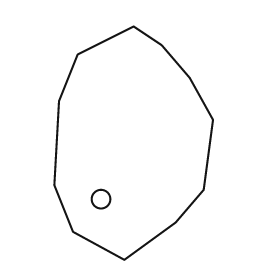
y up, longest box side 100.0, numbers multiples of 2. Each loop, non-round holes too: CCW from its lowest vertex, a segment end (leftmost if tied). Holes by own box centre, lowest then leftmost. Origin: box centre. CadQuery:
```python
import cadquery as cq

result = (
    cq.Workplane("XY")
    .moveTo(-4.0, -50.0)
    .lineTo(18.0, -34.0)
    .lineTo(30.0, -20.0)
    .lineTo(34.0, 10.0)
    .lineTo(24.0, 28.0)
    .lineTo(12.0, 42.0)
    .lineTo(0.0, 50.0)
    .lineTo(-24.0, 38.0)
    .lineTo(-32.0, 18.0)
    .lineTo(-34.0, -18.0)
    .lineTo(-26.0, -38.0)
    .close()
    .moveTo(-14.0, -24.0)
    .circle(4.0)
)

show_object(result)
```